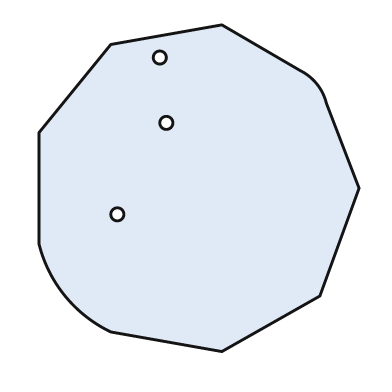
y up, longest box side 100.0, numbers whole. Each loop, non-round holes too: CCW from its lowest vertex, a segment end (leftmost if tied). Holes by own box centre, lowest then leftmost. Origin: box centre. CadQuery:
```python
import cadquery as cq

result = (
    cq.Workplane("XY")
    .moveTo(7.0, -50.0)
    .lineTo(37.0, -33.0)
    .lineTo(49.0, 0.0)
    .lineTo(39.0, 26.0)
    .threePointArc((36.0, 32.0), (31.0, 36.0))
    .lineTo(7.0, 50.0)
    .lineTo(-27.0, 44.0)
    .lineTo(-49.0, 17.0)
    .lineTo(-49.0, -17.0)
    .threePointArc((-41.0, -33.0), (-27.0, -44.0))
    .close()
    .moveTo(-25.0, -8.0)
    .circle(2.0)
    .moveTo(-10.0, 20.0)
    .circle(2.0)
    .moveTo(-12.0, 40.0)
    .circle(2.0)
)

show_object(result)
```